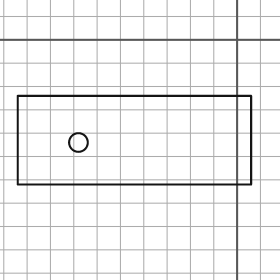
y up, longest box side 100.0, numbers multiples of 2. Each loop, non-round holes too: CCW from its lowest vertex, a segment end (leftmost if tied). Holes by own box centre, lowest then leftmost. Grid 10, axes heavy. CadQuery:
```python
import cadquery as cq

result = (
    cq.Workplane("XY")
    .moveTo(-94.0, -62.0)
    .lineTo(6.0, -62.0)
    .lineTo(6.0, -24.0)
    .lineTo(-94.0, -24.0)
    .close()
    .moveTo(-68.0, -44.0)
    .circle(4.0)
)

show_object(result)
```